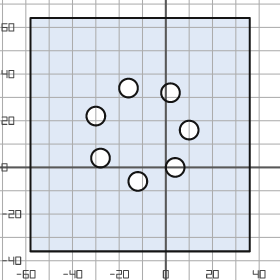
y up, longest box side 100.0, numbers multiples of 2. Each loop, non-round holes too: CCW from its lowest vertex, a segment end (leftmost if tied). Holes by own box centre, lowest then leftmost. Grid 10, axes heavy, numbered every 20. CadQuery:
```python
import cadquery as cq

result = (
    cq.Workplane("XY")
    .moveTo(-58.0, -36.0)
    .lineTo(36.0, -36.0)
    .lineTo(36.0, 64.0)
    .lineTo(-58.0, 64.0)
    .close()
    .moveTo(-12.0, -6.0)
    .circle(4.0)
    .moveTo(4.0, 0.0)
    .circle(4.0)
    .moveTo(-28.0, 4.0)
    .circle(4.0)
    .moveTo(10.0, 16.0)
    .circle(4.0)
    .moveTo(-30.0, 22.0)
    .circle(4.0)
    .moveTo(2.0, 32.0)
    .circle(4.0)
    .moveTo(-16.0, 34.0)
    .circle(4.0)
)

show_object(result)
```